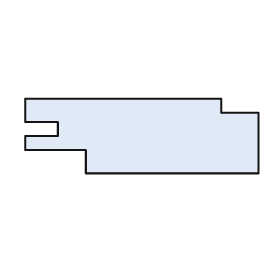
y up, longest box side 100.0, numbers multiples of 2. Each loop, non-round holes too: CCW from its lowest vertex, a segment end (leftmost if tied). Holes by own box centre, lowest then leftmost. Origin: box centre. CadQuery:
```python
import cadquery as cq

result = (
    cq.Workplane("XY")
    .moveTo(-24.0, -16.0)
    .lineTo(50.0, -16.0)
    .lineTo(50.0, 10.0)
    .lineTo(34.0, 10.0)
    .lineTo(34.0, 16.0)
    .lineTo(-50.0, 16.0)
    .lineTo(-50.0, 6.0)
    .lineTo(-36.0, 6.0)
    .lineTo(-36.0, 0.0)
    .lineTo(-50.0, 0.0)
    .lineTo(-50.0, -6.0)
    .lineTo(-24.0, -6.0)
    .close()
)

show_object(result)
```